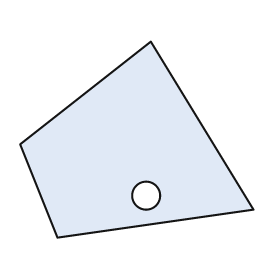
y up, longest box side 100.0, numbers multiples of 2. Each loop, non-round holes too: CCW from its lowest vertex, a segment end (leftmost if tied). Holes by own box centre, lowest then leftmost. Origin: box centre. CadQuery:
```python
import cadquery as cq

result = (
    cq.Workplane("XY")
    .moveTo(-34.0, -42.0)
    .lineTo(50.0, -30.0)
    .lineTo(6.0, 42.0)
    .lineTo(-50.0, -2.0)
    .close()
    .moveTo(4.0, -24.0)
    .circle(6.0)
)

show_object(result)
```